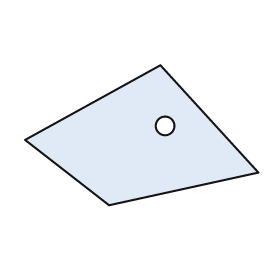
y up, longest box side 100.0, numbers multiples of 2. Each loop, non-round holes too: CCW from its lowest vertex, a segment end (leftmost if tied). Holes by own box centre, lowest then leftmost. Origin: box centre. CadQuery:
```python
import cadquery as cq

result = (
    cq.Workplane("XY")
    .moveTo(-14.0, -30.0)
    .lineTo(50.0, -16.0)
    .lineTo(8.0, 30.0)
    .lineTo(-50.0, -2.0)
    .close()
    .moveTo(10.0, 4.0)
    .circle(4.0)
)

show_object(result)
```